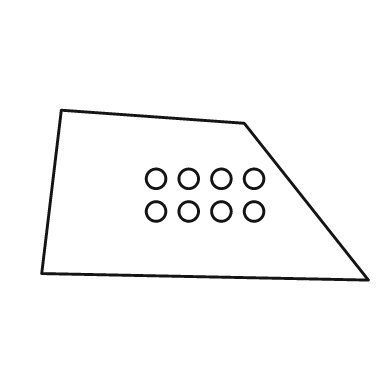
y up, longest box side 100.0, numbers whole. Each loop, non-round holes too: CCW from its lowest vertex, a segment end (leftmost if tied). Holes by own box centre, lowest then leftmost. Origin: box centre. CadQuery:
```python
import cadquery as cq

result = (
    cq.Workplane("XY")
    .moveTo(50.0, -26.0)
    .lineTo(12.0, 22.0)
    .lineTo(-44.0, 26.0)
    .lineTo(-50.0, -24.0)
    .close()
    .moveTo(-15.0, -5.0)
    .circle(3.0)
    .moveTo(-5.0, -5.0)
    .circle(3.0)
    .moveTo(5.0, -5.0)
    .circle(3.0)
    .moveTo(15.0, -5.0)
    .circle(3.0)
    .moveTo(-15.0, 5.0)
    .circle(3.0)
    .moveTo(-5.0, 5.0)
    .circle(3.0)
    .moveTo(5.0, 5.0)
    .circle(3.0)
    .moveTo(15.0, 5.0)
    .circle(3.0)
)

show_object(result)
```